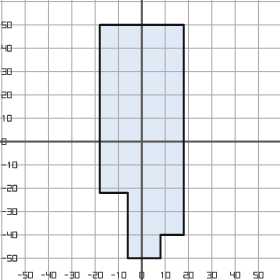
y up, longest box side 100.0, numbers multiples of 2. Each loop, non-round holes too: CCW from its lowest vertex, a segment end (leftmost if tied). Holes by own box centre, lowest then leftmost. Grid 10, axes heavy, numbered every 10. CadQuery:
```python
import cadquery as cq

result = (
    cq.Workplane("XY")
    .moveTo(-6.0, -50.0)
    .lineTo(8.0, -50.0)
    .lineTo(8.0, -40.0)
    .lineTo(18.0, -40.0)
    .lineTo(18.0, 50.0)
    .lineTo(-18.0, 50.0)
    .lineTo(-18.0, -22.0)
    .lineTo(-6.0, -22.0)
    .close()
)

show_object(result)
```